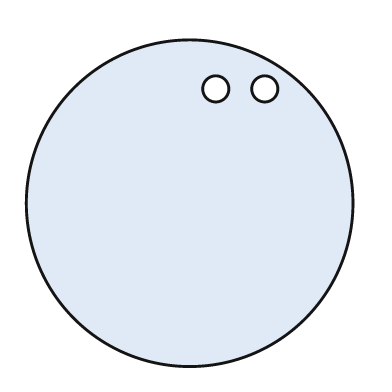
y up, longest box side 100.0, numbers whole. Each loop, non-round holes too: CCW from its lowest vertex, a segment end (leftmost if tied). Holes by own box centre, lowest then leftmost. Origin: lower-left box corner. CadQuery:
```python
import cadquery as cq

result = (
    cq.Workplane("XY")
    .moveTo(50.0, 50.0)
    .circle(50.0)
    .moveTo(58.0, 85.0)
    .circle(4.0)
    .moveTo(73.0, 85.0)
    .circle(4.0)
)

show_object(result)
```